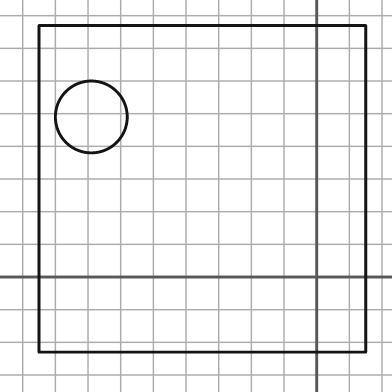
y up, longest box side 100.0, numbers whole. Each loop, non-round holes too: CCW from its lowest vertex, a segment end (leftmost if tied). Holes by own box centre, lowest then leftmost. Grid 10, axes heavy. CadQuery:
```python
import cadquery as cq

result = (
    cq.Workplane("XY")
    .moveTo(-85.0, -23.0)
    .lineTo(15.0, -23.0)
    .lineTo(15.0, 77.0)
    .lineTo(-85.0, 77.0)
    .close()
    .moveTo(-69.0, 49.0)
    .circle(11.0)
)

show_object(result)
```